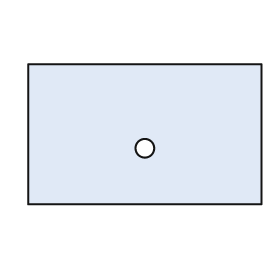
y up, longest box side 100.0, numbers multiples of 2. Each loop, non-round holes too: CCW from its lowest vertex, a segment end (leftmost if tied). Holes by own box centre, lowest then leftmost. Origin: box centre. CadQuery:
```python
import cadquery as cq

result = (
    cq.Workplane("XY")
    .moveTo(-50.0, -30.0)
    .lineTo(50.0, -30.0)
    .lineTo(50.0, 30.0)
    .lineTo(-50.0, 30.0)
    .close()
    .moveTo(0.0, -6.0)
    .circle(4.0)
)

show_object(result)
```